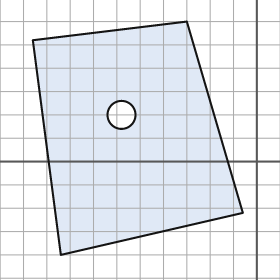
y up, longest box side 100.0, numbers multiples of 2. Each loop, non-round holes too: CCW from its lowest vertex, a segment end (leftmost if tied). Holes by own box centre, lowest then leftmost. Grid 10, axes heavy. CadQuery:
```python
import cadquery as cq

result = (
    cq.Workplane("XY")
    .moveTo(-84.0, -40.0)
    .lineTo(-6.0, -22.0)
    .lineTo(-30.0, 60.0)
    .lineTo(-96.0, 52.0)
    .close()
    .moveTo(-58.0, 20.0)
    .circle(6.0)
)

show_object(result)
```